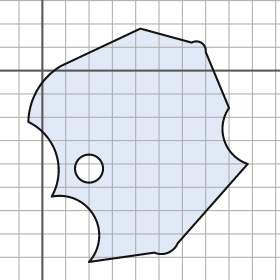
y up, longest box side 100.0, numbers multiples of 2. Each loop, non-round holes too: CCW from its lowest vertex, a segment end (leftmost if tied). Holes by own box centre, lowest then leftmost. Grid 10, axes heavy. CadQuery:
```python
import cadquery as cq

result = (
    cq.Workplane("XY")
    .moveTo(20.0, -82.0)
    .lineTo(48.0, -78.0)
    .threePointArc((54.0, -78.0), (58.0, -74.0))
    .lineTo(88.0, -40.0)
    .threePointArc((78.0, -30.0), (80.0, -16.0))
    .lineTo(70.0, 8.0)
    .threePointArc((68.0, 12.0), (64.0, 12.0))
    .lineTo(42.0, 18.0)
    .lineTo(8.0, 2.0)
    .threePointArc((-2.0, -8.0), (-6.0, -22.0))
    .threePointArc((6.0, -36.0), (4.0, -54.0))
    .threePointArc((22.0, -62.0), (20.0, -82.0))
    .close()
    .moveTo(20.0, -42.0)
    .circle(6.0)
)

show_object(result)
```